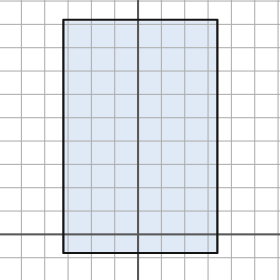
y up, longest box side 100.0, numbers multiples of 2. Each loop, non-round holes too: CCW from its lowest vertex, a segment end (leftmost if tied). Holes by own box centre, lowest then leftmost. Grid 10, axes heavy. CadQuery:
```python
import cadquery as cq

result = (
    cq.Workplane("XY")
    .moveTo(-32.0, -8.0)
    .lineTo(34.0, -8.0)
    .lineTo(34.0, 92.0)
    .lineTo(-32.0, 92.0)
    .close()
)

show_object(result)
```